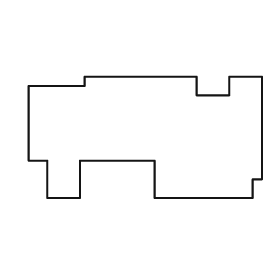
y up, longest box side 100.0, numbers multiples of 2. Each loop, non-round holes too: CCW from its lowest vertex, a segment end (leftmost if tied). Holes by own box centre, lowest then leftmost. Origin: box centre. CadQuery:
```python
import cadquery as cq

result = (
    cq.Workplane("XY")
    .moveTo(-42.0, -26.0)
    .lineTo(-28.0, -26.0)
    .lineTo(-28.0, -10.0)
    .lineTo(4.0, -10.0)
    .lineTo(4.0, -26.0)
    .lineTo(46.0, -26.0)
    .lineTo(46.0, -18.0)
    .lineTo(50.0, -18.0)
    .lineTo(50.0, 26.0)
    .lineTo(36.0, 26.0)
    .lineTo(36.0, 18.0)
    .lineTo(22.0, 18.0)
    .lineTo(22.0, 26.0)
    .lineTo(-26.0, 26.0)
    .lineTo(-26.0, 22.0)
    .lineTo(-50.0, 22.0)
    .lineTo(-50.0, -10.0)
    .lineTo(-42.0, -10.0)
    .close()
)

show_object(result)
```